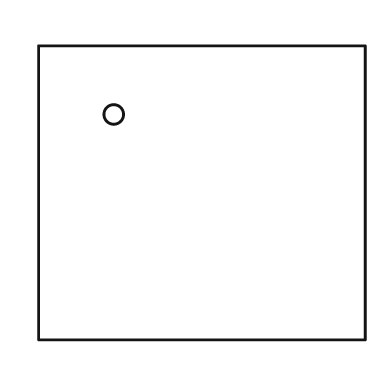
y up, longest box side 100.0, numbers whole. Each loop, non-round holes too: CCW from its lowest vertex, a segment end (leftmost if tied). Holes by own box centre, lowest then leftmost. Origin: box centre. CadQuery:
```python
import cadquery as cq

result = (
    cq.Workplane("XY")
    .moveTo(-50.0, -45.0)
    .lineTo(50.0, -45.0)
    .lineTo(50.0, 45.0)
    .lineTo(-50.0, 45.0)
    .close()
    .moveTo(-27.0, 24.0)
    .circle(3.0)
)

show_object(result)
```